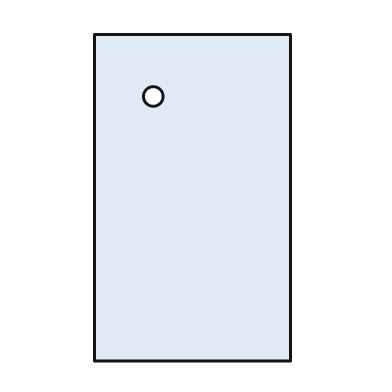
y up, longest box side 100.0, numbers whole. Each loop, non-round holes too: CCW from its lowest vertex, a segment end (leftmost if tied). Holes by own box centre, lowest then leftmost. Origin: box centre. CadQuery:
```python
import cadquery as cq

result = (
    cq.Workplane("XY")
    .moveTo(-30.0, -50.0)
    .lineTo(30.0, -50.0)
    .lineTo(30.0, 50.0)
    .lineTo(-30.0, 50.0)
    .close()
    .moveTo(-12.0, 31.0)
    .circle(3.0)
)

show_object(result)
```